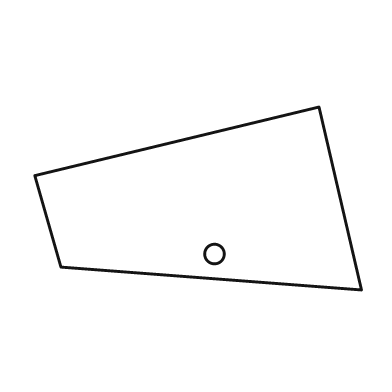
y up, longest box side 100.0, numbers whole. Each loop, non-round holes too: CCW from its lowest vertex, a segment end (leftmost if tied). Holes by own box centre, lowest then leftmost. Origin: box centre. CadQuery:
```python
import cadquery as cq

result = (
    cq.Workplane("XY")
    .moveTo(50.0, -28.0)
    .lineTo(37.0, 28.0)
    .lineTo(-50.0, 7.0)
    .lineTo(-42.0, -21.0)
    .close()
    .moveTo(5.0, -17.0)
    .circle(3.0)
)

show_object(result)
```